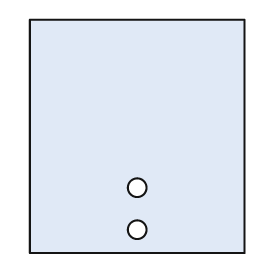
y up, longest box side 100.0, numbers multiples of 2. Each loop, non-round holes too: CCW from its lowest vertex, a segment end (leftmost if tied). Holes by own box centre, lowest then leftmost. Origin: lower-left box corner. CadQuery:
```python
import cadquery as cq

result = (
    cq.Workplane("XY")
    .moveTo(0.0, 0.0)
    .lineTo(92.0, 0.0)
    .lineTo(92.0, 100.0)
    .lineTo(0.0, 100.0)
    .close()
    .moveTo(46.0, 10.0)
    .circle(4.0)
    .moveTo(46.0, 28.0)
    .circle(4.0)
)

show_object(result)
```